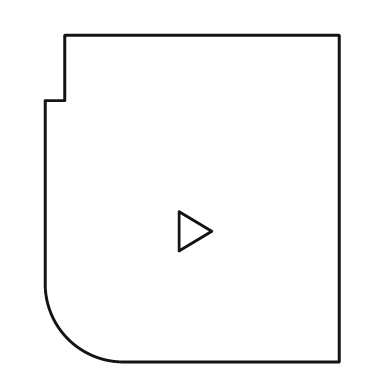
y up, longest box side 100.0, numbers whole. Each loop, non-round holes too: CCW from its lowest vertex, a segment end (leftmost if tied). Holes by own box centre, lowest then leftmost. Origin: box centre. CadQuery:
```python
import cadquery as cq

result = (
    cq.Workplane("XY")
    .moveTo(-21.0, -50.0)
    .lineTo(45.0, -50.0)
    .lineTo(45.0, 50.0)
    .lineTo(-39.0, 50.0)
    .lineTo(-39.0, 30.0)
    .lineTo(-45.0, 30.0)
    .lineTo(-45.0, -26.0)
    .threePointArc((-38.0, -43.0), (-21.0, -50.0))
    .close()
    .moveTo(-4.0, -16.0)
    .lineTo(6.0, -10.0)
    .lineTo(-4.0, -4.0)
    .close()
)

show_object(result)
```